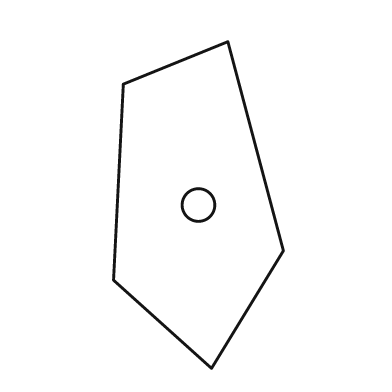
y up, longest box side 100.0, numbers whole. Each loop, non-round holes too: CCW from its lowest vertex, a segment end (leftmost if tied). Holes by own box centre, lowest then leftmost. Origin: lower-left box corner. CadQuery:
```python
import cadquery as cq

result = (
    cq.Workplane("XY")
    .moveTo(30.0, 0.0)
    .lineTo(52.0, 36.0)
    .lineTo(35.0, 100.0)
    .lineTo(3.0, 87.0)
    .lineTo(0.0, 27.0)
    .close()
    .moveTo(26.0, 50.0)
    .circle(5.0)
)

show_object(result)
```